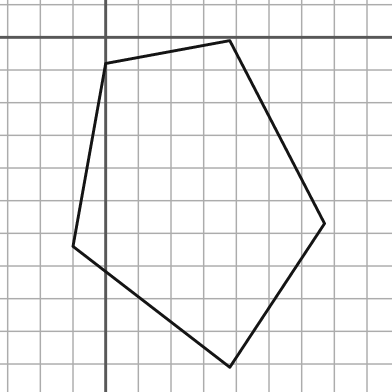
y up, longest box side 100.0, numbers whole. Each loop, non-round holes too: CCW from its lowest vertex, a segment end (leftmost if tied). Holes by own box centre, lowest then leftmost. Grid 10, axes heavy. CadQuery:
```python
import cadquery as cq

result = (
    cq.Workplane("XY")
    .moveTo(38.0, -101.0)
    .lineTo(67.0, -57.0)
    .lineTo(38.0, -1.0)
    .lineTo(0.0, -8.0)
    .lineTo(-10.0, -64.0)
    .close()
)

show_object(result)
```